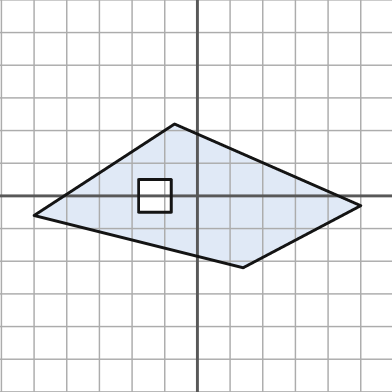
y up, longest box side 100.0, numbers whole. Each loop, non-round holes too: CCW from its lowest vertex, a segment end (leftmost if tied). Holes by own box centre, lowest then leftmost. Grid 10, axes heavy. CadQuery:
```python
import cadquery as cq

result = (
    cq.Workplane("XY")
    .moveTo(14.0, -22.0)
    .lineTo(50.0, -3.0)
    .lineTo(-7.0, 22.0)
    .lineTo(-50.0, -6.0)
    .close()
    .moveTo(-18.0, -5.0)
    .lineTo(-8.0, -5.0)
    .lineTo(-8.0, 5.0)
    .lineTo(-18.0, 5.0)
    .close()
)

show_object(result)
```